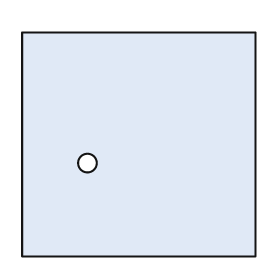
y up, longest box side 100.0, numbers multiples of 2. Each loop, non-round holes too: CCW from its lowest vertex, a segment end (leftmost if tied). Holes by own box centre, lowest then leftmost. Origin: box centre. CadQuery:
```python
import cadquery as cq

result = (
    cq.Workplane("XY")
    .moveTo(-50.0, -48.0)
    .lineTo(50.0, -48.0)
    .lineTo(50.0, 48.0)
    .lineTo(-50.0, 48.0)
    .close()
    .moveTo(-22.0, -8.0)
    .circle(4.0)
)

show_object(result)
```